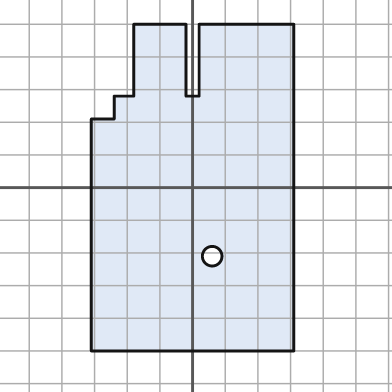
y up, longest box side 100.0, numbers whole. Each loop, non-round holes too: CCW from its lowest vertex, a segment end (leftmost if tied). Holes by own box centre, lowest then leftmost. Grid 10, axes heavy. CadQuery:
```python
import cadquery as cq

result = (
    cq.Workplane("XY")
    .moveTo(-31.0, -50.0)
    .lineTo(31.0, -50.0)
    .lineTo(31.0, 50.0)
    .lineTo(2.0, 50.0)
    .lineTo(2.0, 28.0)
    .lineTo(-2.0, 28.0)
    .lineTo(-2.0, 50.0)
    .lineTo(-18.0, 50.0)
    .lineTo(-18.0, 28.0)
    .lineTo(-24.0, 28.0)
    .lineTo(-24.0, 21.0)
    .lineTo(-31.0, 21.0)
    .close()
    .moveTo(6.0, -21.0)
    .circle(3.0)
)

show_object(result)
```